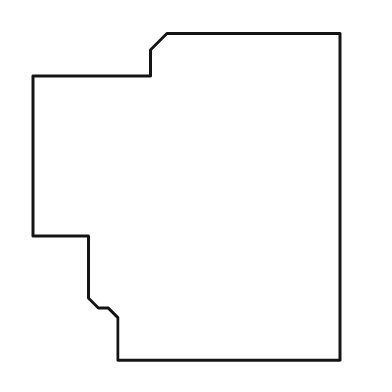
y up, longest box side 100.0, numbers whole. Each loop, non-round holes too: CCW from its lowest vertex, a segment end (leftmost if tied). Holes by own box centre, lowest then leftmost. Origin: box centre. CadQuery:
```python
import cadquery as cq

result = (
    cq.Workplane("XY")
    .moveTo(-21.0, -50.0)
    .lineTo(47.0, -50.0)
    .lineTo(47.0, 50.0)
    .lineTo(-6.0, 50.0)
    .lineTo(-11.0, 45.0)
    .lineTo(-11.0, 37.0)
    .lineTo(-47.0, 37.0)
    .lineTo(-47.0, -12.0)
    .lineTo(-30.0, -12.0)
    .lineTo(-30.0, -31.0)
    .lineTo(-27.0, -34.0)
    .lineTo(-24.0, -34.0)
    .lineTo(-21.0, -37.0)
    .close()
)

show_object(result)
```